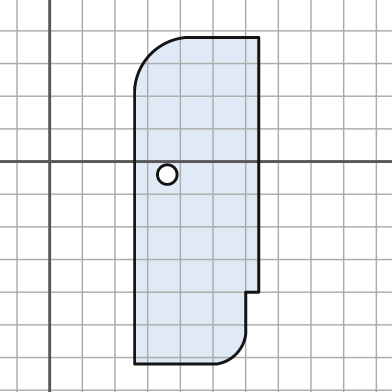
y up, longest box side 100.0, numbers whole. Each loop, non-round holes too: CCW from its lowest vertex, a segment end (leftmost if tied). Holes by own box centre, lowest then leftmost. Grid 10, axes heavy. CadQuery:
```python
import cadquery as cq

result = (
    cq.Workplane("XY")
    .moveTo(26.0, -62.0)
    .lineTo(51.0, -62.0)
    .threePointArc((57.0, -59.0), (60.0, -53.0))
    .lineTo(60.0, -40.0)
    .lineTo(64.0, -40.0)
    .lineTo(64.0, 38.0)
    .lineTo(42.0, 38.0)
    .threePointArc((31.0, 33.0), (26.0, 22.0))
    .close()
    .moveTo(36.0, -4.0)
    .circle(3.0)
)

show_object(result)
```